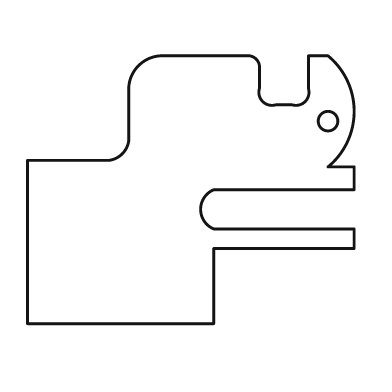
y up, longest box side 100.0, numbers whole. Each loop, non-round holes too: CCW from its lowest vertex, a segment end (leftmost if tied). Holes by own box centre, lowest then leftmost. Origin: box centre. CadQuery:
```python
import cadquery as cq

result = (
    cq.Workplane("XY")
    .moveTo(-50.0, -41.0)
    .lineTo(7.0, -41.0)
    .lineTo(7.0, -18.0)
    .lineTo(50.0, -18.0)
    .lineTo(50.0, -12.0)
    .lineTo(7.0, -12.0)
    .threePointArc((3.0, -6.0), (7.0, 0.0))
    .lineTo(50.0, 0.0)
    .lineTo(50.0, 7.0)
    .lineTo(42.0, 7.0)
    .threePointArc((50.0, 24.0), (42.0, 41.0))
    .lineTo(36.0, 41.0)
    .lineTo(36.0, 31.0)
    .threePointArc((35.0, 27.0), (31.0, 26.0))
    .lineTo(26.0, 26.0)
    .threePointArc((22.0, 27.0), (21.0, 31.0))
    .lineTo(21.0, 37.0)
    .threePointArc((20.0, 40.0), (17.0, 41.0))
    .lineTo(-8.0, 41.0)
    .threePointArc((-16.0, 38.0), (-19.0, 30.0))
    .lineTo(-19.0, 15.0)
    .threePointArc((-21.0, 11.0), (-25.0, 9.0))
    .lineTo(-50.0, 9.0)
    .close()
    .moveTo(42.0, 21.0)
    .circle(3.0)
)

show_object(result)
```